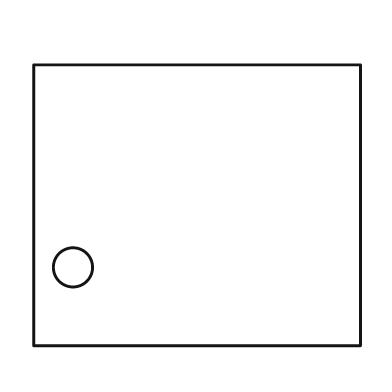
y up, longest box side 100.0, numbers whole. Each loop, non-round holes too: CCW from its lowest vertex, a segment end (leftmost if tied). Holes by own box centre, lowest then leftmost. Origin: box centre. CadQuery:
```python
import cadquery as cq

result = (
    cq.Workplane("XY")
    .moveTo(-50.0, -43.0)
    .lineTo(50.0, -43.0)
    .lineTo(50.0, 43.0)
    .lineTo(-50.0, 43.0)
    .close()
    .moveTo(-38.0, -19.0)
    .circle(6.0)
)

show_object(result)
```